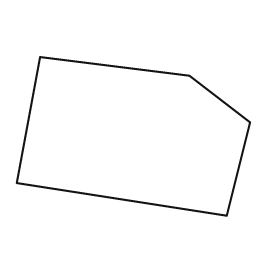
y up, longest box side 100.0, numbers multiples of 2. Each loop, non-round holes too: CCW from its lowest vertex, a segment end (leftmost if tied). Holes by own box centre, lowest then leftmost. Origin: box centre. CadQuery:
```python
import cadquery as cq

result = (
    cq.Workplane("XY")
    .moveTo(40.0, -34.0)
    .lineTo(50.0, 6.0)
    .lineTo(24.0, 26.0)
    .lineTo(-40.0, 34.0)
    .lineTo(-50.0, -20.0)
    .close()
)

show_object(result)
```